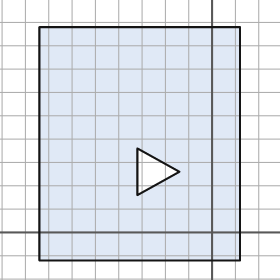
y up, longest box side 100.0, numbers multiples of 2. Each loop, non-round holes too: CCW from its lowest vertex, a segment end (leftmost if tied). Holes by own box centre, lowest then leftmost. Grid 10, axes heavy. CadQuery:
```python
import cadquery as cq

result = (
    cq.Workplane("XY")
    .moveTo(-74.0, -12.0)
    .lineTo(12.0, -12.0)
    .lineTo(12.0, 88.0)
    .lineTo(-74.0, 88.0)
    .close()
    .moveTo(-32.0, 16.0)
    .lineTo(-14.0, 26.0)
    .lineTo(-32.0, 36.0)
    .close()
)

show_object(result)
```